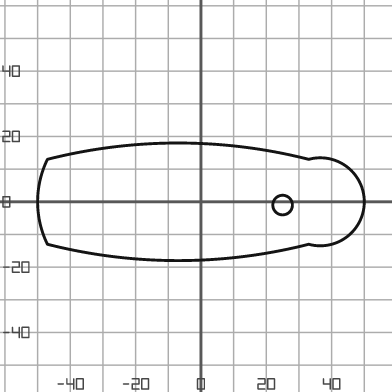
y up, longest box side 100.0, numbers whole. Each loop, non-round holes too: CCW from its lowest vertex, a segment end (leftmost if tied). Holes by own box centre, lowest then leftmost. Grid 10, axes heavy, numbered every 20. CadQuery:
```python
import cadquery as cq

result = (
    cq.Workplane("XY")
    .moveTo(-47.0, -13.0)
    .threePointArc((-7.0, -18.0), (33.0, -13.0))
    .threePointArc((50.0, 0.0), (33.0, 13.0))
    .threePointArc((-7.0, 18.0), (-47.0, 13.0))
    .threePointArc((-50.0, 0.0), (-47.0, -13.0))
    .close()
    .moveTo(25.0, -1.0)
    .circle(3.0)
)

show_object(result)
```